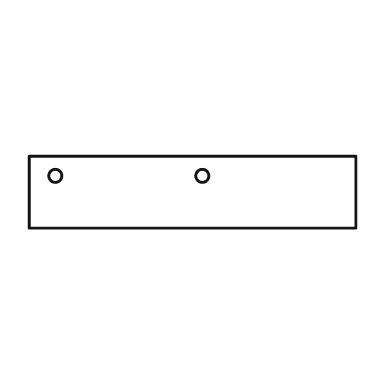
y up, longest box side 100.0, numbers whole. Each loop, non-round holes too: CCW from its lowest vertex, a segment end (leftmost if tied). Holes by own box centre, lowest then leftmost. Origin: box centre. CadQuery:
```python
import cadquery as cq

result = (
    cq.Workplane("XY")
    .moveTo(-50.0, -11.0)
    .lineTo(50.0, -11.0)
    .lineTo(50.0, 11.0)
    .lineTo(-50.0, 11.0)
    .close()
    .moveTo(-42.0, 5.0)
    .circle(2.0)
    .moveTo(3.0, 5.0)
    .circle(2.0)
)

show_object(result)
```